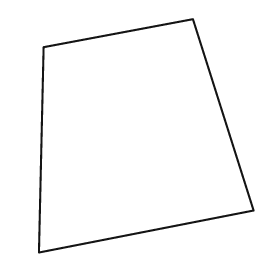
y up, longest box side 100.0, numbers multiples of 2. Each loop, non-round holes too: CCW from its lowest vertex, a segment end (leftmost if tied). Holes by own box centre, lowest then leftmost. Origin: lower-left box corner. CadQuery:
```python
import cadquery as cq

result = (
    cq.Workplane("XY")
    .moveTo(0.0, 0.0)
    .lineTo(92.0, 18.0)
    .lineTo(66.0, 100.0)
    .lineTo(2.0, 88.0)
    .close()
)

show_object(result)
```